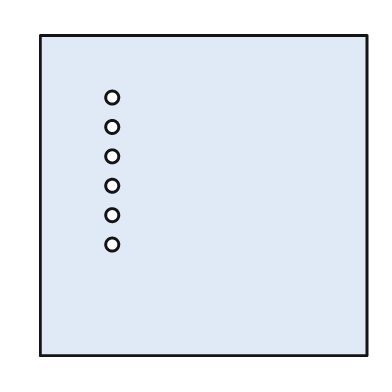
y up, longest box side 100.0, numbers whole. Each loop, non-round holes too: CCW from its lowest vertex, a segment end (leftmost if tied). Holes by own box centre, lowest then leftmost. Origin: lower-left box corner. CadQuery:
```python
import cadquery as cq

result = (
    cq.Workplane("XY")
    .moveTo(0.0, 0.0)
    .lineTo(100.0, 0.0)
    .lineTo(100.0, 98.0)
    .lineTo(0.0, 98.0)
    .close()
    .moveTo(22.0, 34.0)
    .circle(2.0)
    .moveTo(22.0, 43.0)
    .circle(2.0)
    .moveTo(22.0, 52.0)
    .circle(2.0)
    .moveTo(22.0, 61.0)
    .circle(2.0)
    .moveTo(22.0, 70.0)
    .circle(2.0)
    .moveTo(22.0, 79.0)
    .circle(2.0)
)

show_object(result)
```